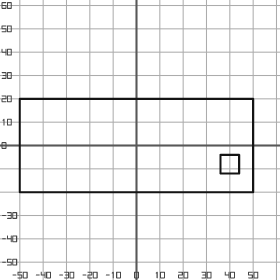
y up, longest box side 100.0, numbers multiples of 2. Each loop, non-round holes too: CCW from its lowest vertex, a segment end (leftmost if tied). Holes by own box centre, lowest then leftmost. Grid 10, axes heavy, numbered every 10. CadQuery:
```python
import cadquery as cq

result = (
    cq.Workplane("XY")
    .moveTo(-50.0, -20.0)
    .lineTo(50.0, -20.0)
    .lineTo(50.0, 20.0)
    .lineTo(-50.0, 20.0)
    .close()
    .moveTo(36.0, -12.0)
    .lineTo(44.0, -12.0)
    .lineTo(44.0, -4.0)
    .lineTo(36.0, -4.0)
    .close()
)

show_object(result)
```